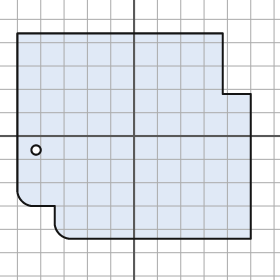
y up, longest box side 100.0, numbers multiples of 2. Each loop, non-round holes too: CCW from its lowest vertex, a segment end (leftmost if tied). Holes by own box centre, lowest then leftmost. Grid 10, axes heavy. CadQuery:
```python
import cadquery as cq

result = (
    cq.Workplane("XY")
    .moveTo(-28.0, -44.0)
    .lineTo(50.0, -44.0)
    .lineTo(50.0, 18.0)
    .lineTo(38.0, 18.0)
    .lineTo(38.0, 44.0)
    .lineTo(-50.0, 44.0)
    .lineTo(-50.0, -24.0)
    .threePointArc((-48.0, -28.0), (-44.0, -30.0))
    .lineTo(-34.0, -30.0)
    .lineTo(-34.0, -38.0)
    .threePointArc((-32.0, -42.0), (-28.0, -44.0))
    .close()
    .moveTo(-42.0, -6.0)
    .circle(2.0)
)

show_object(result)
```